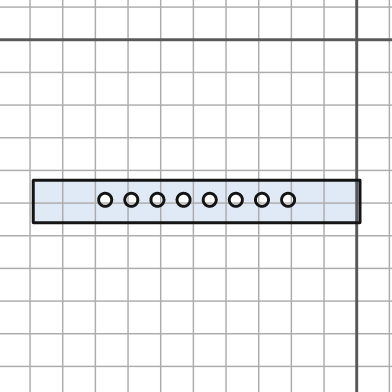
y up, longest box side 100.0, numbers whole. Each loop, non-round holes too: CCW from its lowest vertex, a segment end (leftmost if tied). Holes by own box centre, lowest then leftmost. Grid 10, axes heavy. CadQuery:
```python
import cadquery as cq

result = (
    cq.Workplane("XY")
    .moveTo(-99.0, -56.0)
    .lineTo(1.0, -56.0)
    .lineTo(1.0, -43.0)
    .lineTo(-99.0, -43.0)
    .close()
    .moveTo(-77.0, -49.0)
    .circle(2.0)
    .moveTo(-69.0, -49.0)
    .circle(2.0)
    .moveTo(-61.0, -49.0)
    .circle(2.0)
    .moveTo(-53.0, -49.0)
    .circle(2.0)
    .moveTo(-45.0, -49.0)
    .circle(2.0)
    .moveTo(-37.0, -49.0)
    .circle(2.0)
    .moveTo(-29.0, -49.0)
    .circle(2.0)
    .moveTo(-21.0, -49.0)
    .circle(2.0)
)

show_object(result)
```